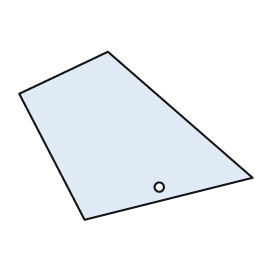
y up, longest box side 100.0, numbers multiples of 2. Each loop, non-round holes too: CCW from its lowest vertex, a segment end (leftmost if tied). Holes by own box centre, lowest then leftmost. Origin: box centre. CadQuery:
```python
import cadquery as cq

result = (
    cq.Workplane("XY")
    .moveTo(-22.0, -36.0)
    .lineTo(50.0, -18.0)
    .lineTo(-12.0, 36.0)
    .lineTo(-50.0, 18.0)
    .close()
    .moveTo(10.0, -22.0)
    .circle(2.0)
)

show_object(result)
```